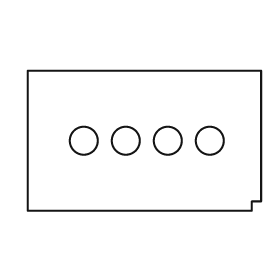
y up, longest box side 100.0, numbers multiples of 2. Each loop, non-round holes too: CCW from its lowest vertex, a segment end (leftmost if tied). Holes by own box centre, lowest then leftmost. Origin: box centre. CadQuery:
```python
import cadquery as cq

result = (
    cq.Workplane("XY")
    .moveTo(-50.0, -30.0)
    .lineTo(46.0, -30.0)
    .lineTo(46.0, -26.0)
    .lineTo(50.0, -26.0)
    .lineTo(50.0, 30.0)
    .lineTo(-50.0, 30.0)
    .close()
    .moveTo(-26.0, 0.0)
    .circle(6.0)
    .moveTo(-8.0, 0.0)
    .circle(6.0)
    .moveTo(10.0, 0.0)
    .circle(6.0)
    .moveTo(28.0, 0.0)
    .circle(6.0)
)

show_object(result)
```